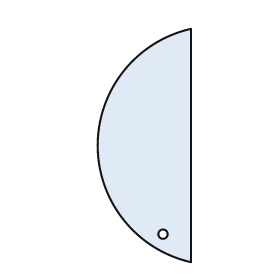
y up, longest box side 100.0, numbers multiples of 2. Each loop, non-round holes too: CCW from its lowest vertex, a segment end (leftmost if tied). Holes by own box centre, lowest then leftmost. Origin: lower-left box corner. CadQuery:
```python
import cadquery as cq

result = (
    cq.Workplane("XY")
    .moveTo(40.0, 0.0)
    .lineTo(40.0, 100.0)
    .threePointArc((0.0, 50.0), (40.0, 0.0))
    .close()
    .moveTo(28.0, 12.0)
    .circle(2.0)
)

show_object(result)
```